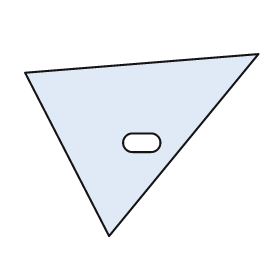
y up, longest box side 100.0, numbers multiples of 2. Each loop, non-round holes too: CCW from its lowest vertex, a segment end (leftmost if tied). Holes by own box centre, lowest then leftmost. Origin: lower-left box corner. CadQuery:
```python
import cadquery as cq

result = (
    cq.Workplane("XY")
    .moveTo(36.0, 0.0)
    .lineTo(100.0, 78.0)
    .lineTo(0.0, 70.0)
    .close()
    .moveTo(46.0, 36.0)
    .lineTo(54.0, 36.0)
    .threePointArc((58.0, 40.0), (54.0, 44.0))
    .lineTo(46.0, 44.0)
    .threePointArc((42.0, 40.0), (46.0, 36.0))
    .close()
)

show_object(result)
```